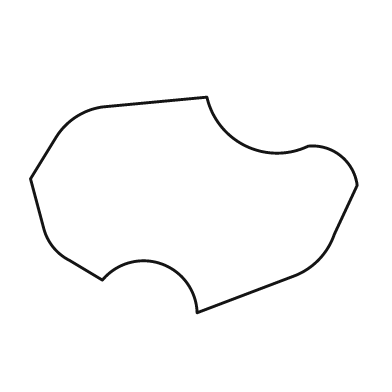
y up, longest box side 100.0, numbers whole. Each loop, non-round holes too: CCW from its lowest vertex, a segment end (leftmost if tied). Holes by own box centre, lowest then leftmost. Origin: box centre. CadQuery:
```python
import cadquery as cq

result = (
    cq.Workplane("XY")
    .moveTo(1.0, -33.0)
    .lineTo(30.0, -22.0)
    .threePointArc((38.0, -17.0), (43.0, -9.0))
    .lineTo(50.0, 6.0)
    .threePointArc((45.0, 15.0), (35.0, 18.0))
    .threePointArc((16.0, 18.0), (4.0, 33.0))
    .lineTo(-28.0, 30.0)
    .threePointArc((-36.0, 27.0), (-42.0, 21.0))
    .lineTo(-50.0, 8.0)
    .lineTo(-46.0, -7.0)
    .threePointArc((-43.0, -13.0), (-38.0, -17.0))
    .lineTo(-28.0, -23.0)
    .threePointArc((-10.0, -18.0), (1.0, -33.0))
    .close()
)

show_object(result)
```